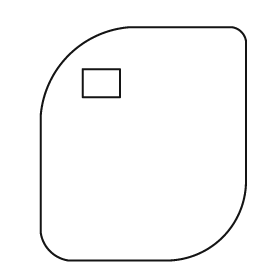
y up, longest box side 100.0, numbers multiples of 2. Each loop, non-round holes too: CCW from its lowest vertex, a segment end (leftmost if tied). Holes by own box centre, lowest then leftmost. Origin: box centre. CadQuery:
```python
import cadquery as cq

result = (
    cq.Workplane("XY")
    .moveTo(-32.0, -50.0)
    .lineTo(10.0, -50.0)
    .threePointArc((34.0, -40.0), (44.0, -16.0))
    .lineTo(44.0, 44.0)
    .threePointArc((42.0, 48.0), (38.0, 50.0))
    .lineTo(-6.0, 50.0)
    .threePointArc((-32.0, 38.0), (-44.0, 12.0))
    .lineTo(-44.0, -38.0)
    .threePointArc((-40.0, -46.0), (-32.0, -50.0))
    .close()
    .moveTo(-26.0, 20.0)
    .lineTo(-10.0, 20.0)
    .lineTo(-10.0, 32.0)
    .lineTo(-26.0, 32.0)
    .close()
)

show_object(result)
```